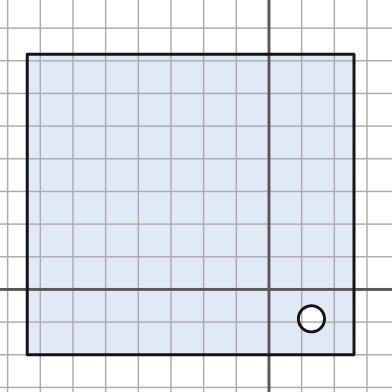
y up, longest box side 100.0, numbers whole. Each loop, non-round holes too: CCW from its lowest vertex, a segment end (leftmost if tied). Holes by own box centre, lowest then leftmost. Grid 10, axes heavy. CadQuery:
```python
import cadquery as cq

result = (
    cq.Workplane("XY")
    .moveTo(-74.0, -20.0)
    .lineTo(26.0, -20.0)
    .lineTo(26.0, 72.0)
    .lineTo(-74.0, 72.0)
    .close()
    .moveTo(13.0, -9.0)
    .circle(4.0)
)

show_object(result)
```